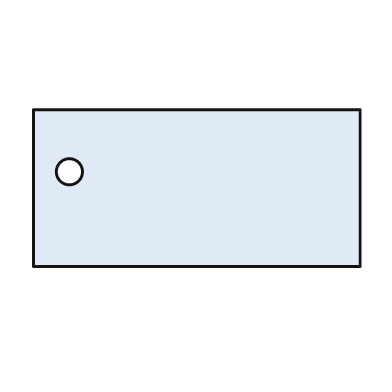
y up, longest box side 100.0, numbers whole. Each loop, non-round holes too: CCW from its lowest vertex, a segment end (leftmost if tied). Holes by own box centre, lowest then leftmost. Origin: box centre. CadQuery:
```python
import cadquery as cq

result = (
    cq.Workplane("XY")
    .moveTo(-50.0, -24.0)
    .lineTo(50.0, -24.0)
    .lineTo(50.0, 24.0)
    .lineTo(-50.0, 24.0)
    .close()
    .moveTo(-39.0, 5.0)
    .circle(4.0)
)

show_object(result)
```